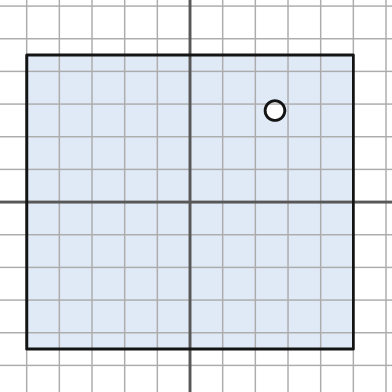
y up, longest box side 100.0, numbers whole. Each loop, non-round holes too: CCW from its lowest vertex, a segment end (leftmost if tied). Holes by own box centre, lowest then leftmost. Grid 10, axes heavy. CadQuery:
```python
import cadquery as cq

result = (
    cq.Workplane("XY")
    .moveTo(-50.0, -45.0)
    .lineTo(50.0, -45.0)
    .lineTo(50.0, 45.0)
    .lineTo(-50.0, 45.0)
    .close()
    .moveTo(26.0, 28.0)
    .circle(3.0)
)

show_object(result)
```